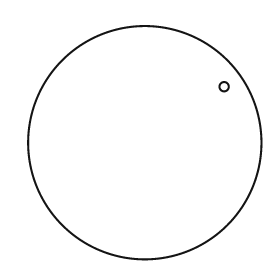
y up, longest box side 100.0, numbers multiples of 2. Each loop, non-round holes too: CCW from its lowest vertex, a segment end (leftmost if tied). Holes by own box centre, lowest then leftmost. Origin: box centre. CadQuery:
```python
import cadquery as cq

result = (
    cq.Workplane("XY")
    .moveTo(0.0, 0.0)
    .circle(50.0)
    .moveTo(34.0, 24.0)
    .circle(2.0)
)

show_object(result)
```